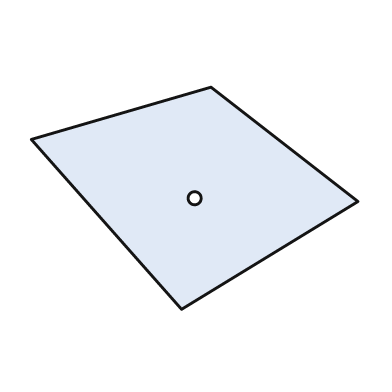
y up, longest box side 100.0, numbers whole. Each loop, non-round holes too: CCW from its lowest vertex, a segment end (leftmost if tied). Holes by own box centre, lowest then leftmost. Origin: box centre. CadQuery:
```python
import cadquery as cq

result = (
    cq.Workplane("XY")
    .moveTo(-4.0, -34.0)
    .lineTo(50.0, -1.0)
    .lineTo(5.0, 34.0)
    .lineTo(-50.0, 18.0)
    .close()
    .moveTo(0.0, 0.0)
    .circle(2.0)
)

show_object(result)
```